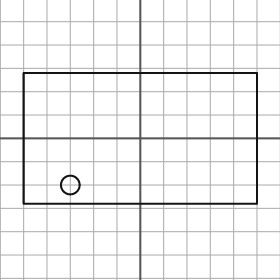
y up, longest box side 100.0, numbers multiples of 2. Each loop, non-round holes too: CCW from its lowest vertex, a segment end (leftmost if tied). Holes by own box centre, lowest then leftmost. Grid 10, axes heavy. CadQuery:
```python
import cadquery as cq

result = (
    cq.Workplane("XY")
    .moveTo(-50.0, -28.0)
    .lineTo(50.0, -28.0)
    .lineTo(50.0, 28.0)
    .lineTo(-50.0, 28.0)
    .close()
    .moveTo(-30.0, -20.0)
    .circle(4.0)
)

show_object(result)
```